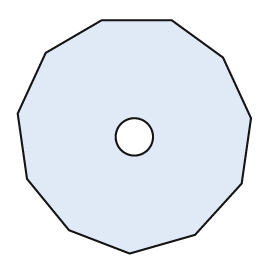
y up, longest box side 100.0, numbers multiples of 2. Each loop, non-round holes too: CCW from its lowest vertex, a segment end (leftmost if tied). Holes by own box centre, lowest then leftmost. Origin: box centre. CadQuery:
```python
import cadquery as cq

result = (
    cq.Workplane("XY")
    .moveTo(-2.0, -50.0)
    .lineTo(26.0, -42.0)
    .lineTo(46.0, -20.0)
    .lineTo(50.0, 8.0)
    .lineTo(38.0, 34.0)
    .lineTo(16.0, 50.0)
    .lineTo(-14.0, 50.0)
    .lineTo(-38.0, 36.0)
    .lineTo(-50.0, 10.0)
    .lineTo(-46.0, -18.0)
    .lineTo(-28.0, -40.0)
    .close()
    .moveTo(0.0, 0.0)
    .circle(8.0)
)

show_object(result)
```